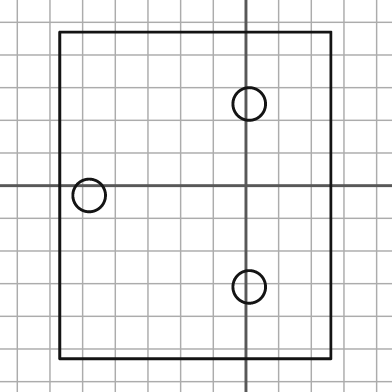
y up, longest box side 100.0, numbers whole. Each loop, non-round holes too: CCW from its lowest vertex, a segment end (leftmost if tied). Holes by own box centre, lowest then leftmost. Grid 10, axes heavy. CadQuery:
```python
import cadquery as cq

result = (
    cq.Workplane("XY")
    .moveTo(-57.0, -53.0)
    .lineTo(26.0, -53.0)
    .lineTo(26.0, 47.0)
    .lineTo(-57.0, 47.0)
    .close()
    .moveTo(1.0, -31.0)
    .circle(5.0)
    .moveTo(-48.0, -3.0)
    .circle(5.0)
    .moveTo(1.0, 25.0)
    .circle(5.0)
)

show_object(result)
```